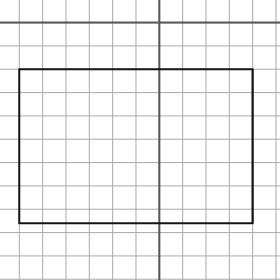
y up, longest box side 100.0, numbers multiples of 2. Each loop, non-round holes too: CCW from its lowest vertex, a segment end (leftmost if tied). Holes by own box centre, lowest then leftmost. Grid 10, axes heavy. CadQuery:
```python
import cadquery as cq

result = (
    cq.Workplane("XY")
    .moveTo(-60.0, -86.0)
    .lineTo(40.0, -86.0)
    .lineTo(40.0, -20.0)
    .lineTo(-60.0, -20.0)
    .close()
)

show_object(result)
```